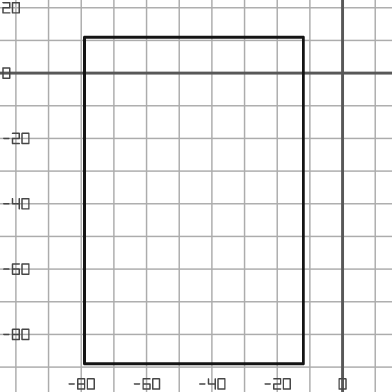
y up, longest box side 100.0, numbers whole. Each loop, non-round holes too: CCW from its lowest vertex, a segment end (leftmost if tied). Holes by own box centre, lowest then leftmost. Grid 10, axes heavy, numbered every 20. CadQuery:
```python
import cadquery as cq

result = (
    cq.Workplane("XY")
    .moveTo(-79.0, -89.0)
    .lineTo(-12.0, -89.0)
    .lineTo(-12.0, 11.0)
    .lineTo(-79.0, 11.0)
    .close()
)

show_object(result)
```